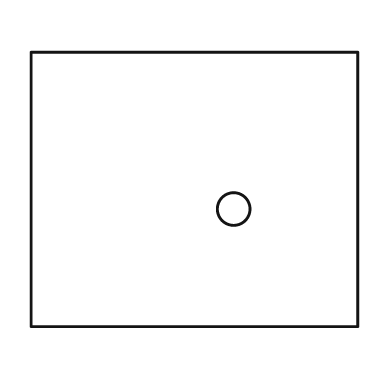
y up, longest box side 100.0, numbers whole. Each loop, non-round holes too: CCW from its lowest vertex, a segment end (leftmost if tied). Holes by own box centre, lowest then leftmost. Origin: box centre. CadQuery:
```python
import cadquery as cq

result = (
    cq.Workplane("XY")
    .moveTo(-50.0, -42.0)
    .lineTo(50.0, -42.0)
    .lineTo(50.0, 42.0)
    .lineTo(-50.0, 42.0)
    .close()
    .moveTo(12.0, -6.0)
    .circle(5.0)
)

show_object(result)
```